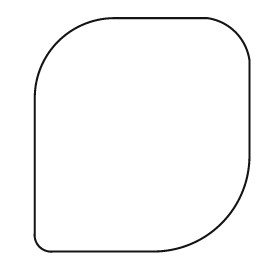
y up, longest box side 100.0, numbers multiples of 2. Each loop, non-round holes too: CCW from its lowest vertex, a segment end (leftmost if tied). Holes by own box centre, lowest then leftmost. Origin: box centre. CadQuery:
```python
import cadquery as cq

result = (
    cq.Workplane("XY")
    .moveTo(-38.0, -50.0)
    .lineTo(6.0, -50.0)
    .threePointArc((34.0, -38.0), (46.0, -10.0))
    .lineTo(46.0, 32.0)
    .threePointArc((40.0, 44.0), (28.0, 50.0))
    .lineTo(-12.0, 50.0)
    .threePointArc((-36.0, 40.0), (-46.0, 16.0))
    .lineTo(-46.0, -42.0)
    .threePointArc((-44.0, -48.0), (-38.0, -50.0))
    .close()
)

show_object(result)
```